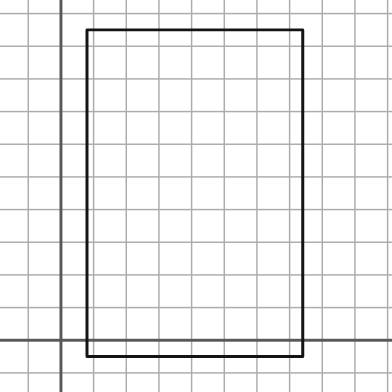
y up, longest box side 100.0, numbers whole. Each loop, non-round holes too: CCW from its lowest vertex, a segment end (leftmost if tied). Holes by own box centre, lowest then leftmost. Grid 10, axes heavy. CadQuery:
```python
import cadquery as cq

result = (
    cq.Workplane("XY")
    .moveTo(8.0, -5.0)
    .lineTo(74.0, -5.0)
    .lineTo(74.0, 95.0)
    .lineTo(8.0, 95.0)
    .close()
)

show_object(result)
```